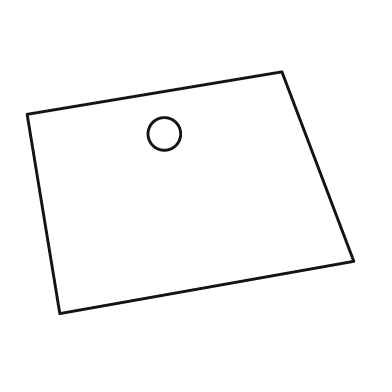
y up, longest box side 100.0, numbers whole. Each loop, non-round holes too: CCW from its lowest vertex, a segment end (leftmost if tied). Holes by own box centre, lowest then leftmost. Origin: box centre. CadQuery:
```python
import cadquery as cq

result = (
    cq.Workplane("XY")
    .moveTo(-40.0, -37.0)
    .lineTo(50.0, -21.0)
    .lineTo(28.0, 37.0)
    .lineTo(-50.0, 24.0)
    .close()
    .moveTo(-8.0, 18.0)
    .circle(5.0)
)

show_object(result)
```